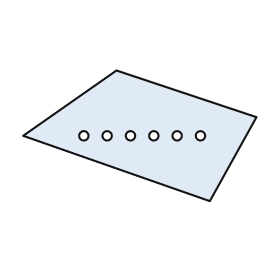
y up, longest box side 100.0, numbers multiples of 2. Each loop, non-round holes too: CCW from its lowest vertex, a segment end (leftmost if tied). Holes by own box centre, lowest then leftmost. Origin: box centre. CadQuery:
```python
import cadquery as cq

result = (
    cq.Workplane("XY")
    .moveTo(30.0, -28.0)
    .lineTo(50.0, 8.0)
    .lineTo(-10.0, 28.0)
    .lineTo(-50.0, 0.0)
    .close()
    .moveTo(-24.0, 0.0)
    .circle(2.0)
    .moveTo(-14.0, 0.0)
    .circle(2.0)
    .moveTo(-4.0, 0.0)
    .circle(2.0)
    .moveTo(6.0, 0.0)
    .circle(2.0)
    .moveTo(16.0, 0.0)
    .circle(2.0)
    .moveTo(26.0, 0.0)
    .circle(2.0)
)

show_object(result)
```